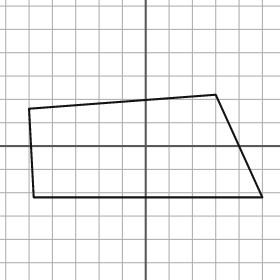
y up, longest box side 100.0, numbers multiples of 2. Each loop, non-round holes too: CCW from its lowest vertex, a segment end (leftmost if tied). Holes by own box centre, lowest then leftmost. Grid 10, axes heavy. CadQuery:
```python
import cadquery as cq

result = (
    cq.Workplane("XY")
    .moveTo(-48.0, -22.0)
    .lineTo(50.0, -22.0)
    .lineTo(30.0, 22.0)
    .lineTo(-50.0, 16.0)
    .close()
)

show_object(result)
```